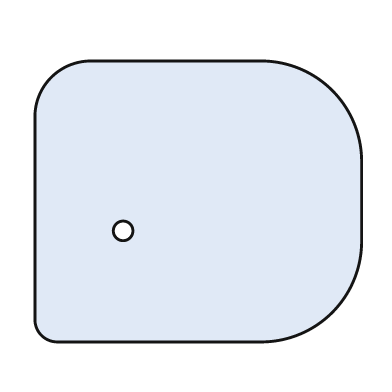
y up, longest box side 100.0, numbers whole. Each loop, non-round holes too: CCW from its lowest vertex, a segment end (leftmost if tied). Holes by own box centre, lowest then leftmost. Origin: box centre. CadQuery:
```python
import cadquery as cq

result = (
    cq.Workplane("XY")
    .moveTo(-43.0, -43.0)
    .lineTo(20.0, -43.0)
    .threePointArc((41.0, -34.0), (50.0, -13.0))
    .lineTo(50.0, 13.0)
    .threePointArc((41.0, 34.0), (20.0, 43.0))
    .lineTo(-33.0, 43.0)
    .threePointArc((-45.0, 38.0), (-50.0, 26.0))
    .lineTo(-50.0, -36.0)
    .threePointArc((-48.0, -41.0), (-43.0, -43.0))
    .close()
    .moveTo(-23.0, -9.0)
    .circle(3.0)
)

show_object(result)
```